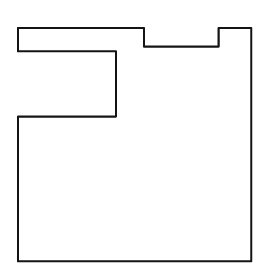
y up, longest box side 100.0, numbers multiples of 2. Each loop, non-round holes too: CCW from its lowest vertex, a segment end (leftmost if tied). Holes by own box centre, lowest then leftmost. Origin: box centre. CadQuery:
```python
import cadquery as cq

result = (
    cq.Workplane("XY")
    .moveTo(-50.0, -50.0)
    .lineTo(50.0, -50.0)
    .lineTo(50.0, 50.0)
    .lineTo(36.0, 50.0)
    .lineTo(36.0, 42.0)
    .lineTo(4.0, 42.0)
    .lineTo(4.0, 50.0)
    .lineTo(-50.0, 50.0)
    .lineTo(-50.0, 40.0)
    .lineTo(-8.0, 40.0)
    .lineTo(-8.0, 12.0)
    .lineTo(-50.0, 12.0)
    .close()
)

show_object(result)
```